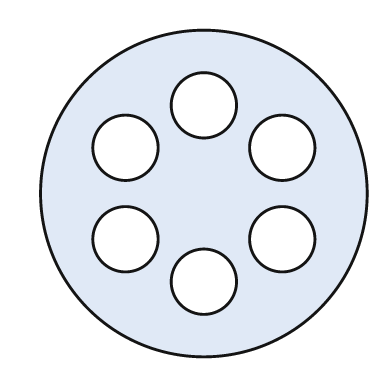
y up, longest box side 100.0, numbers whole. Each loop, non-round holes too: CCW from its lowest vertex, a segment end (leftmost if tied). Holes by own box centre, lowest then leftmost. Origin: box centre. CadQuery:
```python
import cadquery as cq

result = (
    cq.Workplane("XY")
    .moveTo(0.0, 0.0)
    .circle(50.0)
    .moveTo(0.0, -27.0)
    .circle(10.0)
    .moveTo(-24.0, -14.0)
    .circle(10.0)
    .moveTo(24.0, -14.0)
    .circle(10.0)
    .moveTo(-24.0, 14.0)
    .circle(10.0)
    .moveTo(24.0, 14.0)
    .circle(10.0)
    .moveTo(0.0, 27.0)
    .circle(10.0)
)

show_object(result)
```